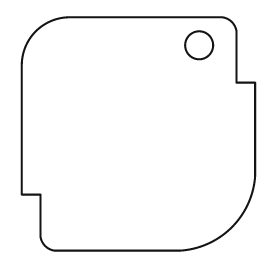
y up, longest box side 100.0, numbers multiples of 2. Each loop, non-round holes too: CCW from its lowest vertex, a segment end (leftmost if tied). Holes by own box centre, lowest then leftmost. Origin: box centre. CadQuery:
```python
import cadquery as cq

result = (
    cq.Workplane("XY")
    .moveTo(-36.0, -50.0)
    .lineTo(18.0, -50.0)
    .threePointArc((40.0, -40.0), (50.0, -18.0))
    .lineTo(50.0, 22.0)
    .lineTo(42.0, 22.0)
    .lineTo(42.0, 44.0)
    .threePointArc((40.0, 48.0), (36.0, 50.0))
    .lineTo(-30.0, 50.0)
    .threePointArc((-44.0, 44.0), (-50.0, 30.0))
    .lineTo(-50.0, -26.0)
    .lineTo(-42.0, -26.0)
    .lineTo(-42.0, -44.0)
    .threePointArc((-40.0, -48.0), (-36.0, -50.0))
    .close()
    .moveTo(26.0, 38.0)
    .circle(6.0)
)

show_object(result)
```